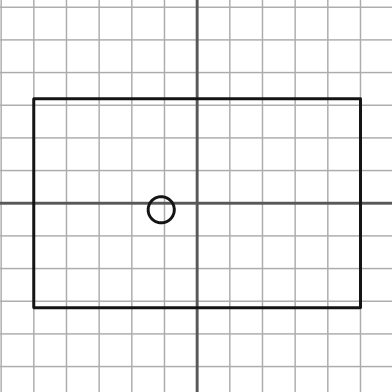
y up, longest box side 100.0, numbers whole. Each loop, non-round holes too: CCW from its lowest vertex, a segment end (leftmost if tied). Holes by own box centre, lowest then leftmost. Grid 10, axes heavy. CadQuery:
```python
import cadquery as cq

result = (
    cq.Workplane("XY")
    .moveTo(-50.0, -32.0)
    .lineTo(50.0, -32.0)
    .lineTo(50.0, 32.0)
    .lineTo(-50.0, 32.0)
    .close()
    .moveTo(-11.0, -2.0)
    .circle(4.0)
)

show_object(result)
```